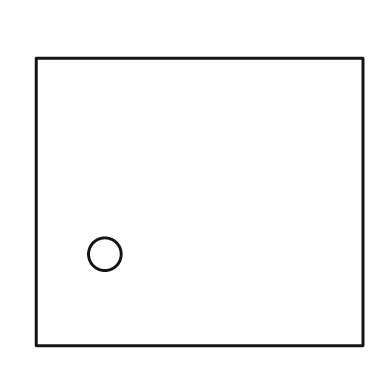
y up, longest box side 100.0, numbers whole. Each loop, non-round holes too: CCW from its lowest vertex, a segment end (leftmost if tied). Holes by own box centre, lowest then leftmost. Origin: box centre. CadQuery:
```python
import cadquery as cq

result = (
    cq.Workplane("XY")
    .moveTo(-50.0, -44.0)
    .lineTo(50.0, -44.0)
    .lineTo(50.0, 44.0)
    .lineTo(-50.0, 44.0)
    .close()
    .moveTo(-29.0, -16.0)
    .circle(5.0)
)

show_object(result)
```